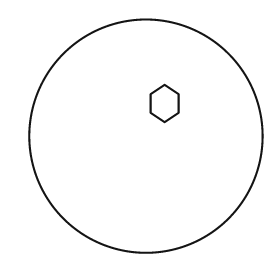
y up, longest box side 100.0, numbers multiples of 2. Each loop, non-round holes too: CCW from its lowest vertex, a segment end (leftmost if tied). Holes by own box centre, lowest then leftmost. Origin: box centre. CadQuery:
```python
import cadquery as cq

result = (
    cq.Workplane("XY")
    .moveTo(0.0, 0.0)
    .circle(50.0)
    .moveTo(8.0, 6.0)
    .lineTo(14.0, 10.0)
    .lineTo(14.0, 18.0)
    .lineTo(8.0, 22.0)
    .lineTo(2.0, 18.0)
    .lineTo(2.0, 10.0)
    .close()
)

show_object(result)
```